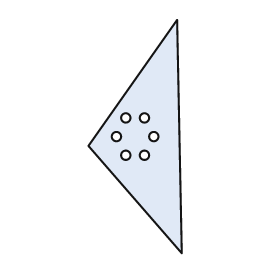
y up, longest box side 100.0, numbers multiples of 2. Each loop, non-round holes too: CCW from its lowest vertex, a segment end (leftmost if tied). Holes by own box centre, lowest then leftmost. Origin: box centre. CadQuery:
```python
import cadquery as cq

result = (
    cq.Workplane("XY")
    .moveTo(20.0, -50.0)
    .lineTo(18.0, 50.0)
    .lineTo(-20.0, -4.0)
    .close()
    .moveTo(-4.0, -8.0)
    .circle(2.0)
    .moveTo(4.0, -8.0)
    .circle(2.0)
    .moveTo(-8.0, 0.0)
    .circle(2.0)
    .moveTo(8.0, 0.0)
    .circle(2.0)
    .moveTo(-4.0, 8.0)
    .circle(2.0)
    .moveTo(4.0, 8.0)
    .circle(2.0)
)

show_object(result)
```